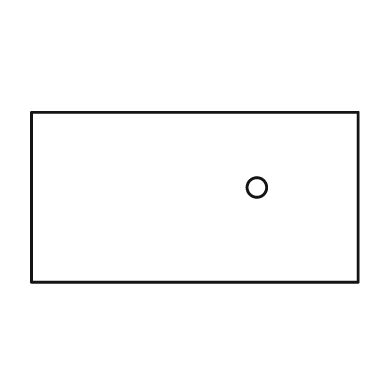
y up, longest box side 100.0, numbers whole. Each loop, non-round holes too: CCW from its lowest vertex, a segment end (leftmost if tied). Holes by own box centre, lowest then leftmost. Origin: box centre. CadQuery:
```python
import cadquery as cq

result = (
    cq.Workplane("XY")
    .moveTo(-50.0, -26.0)
    .lineTo(50.0, -26.0)
    .lineTo(50.0, 26.0)
    .lineTo(-50.0, 26.0)
    .close()
    .moveTo(19.0, 3.0)
    .circle(3.0)
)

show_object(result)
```